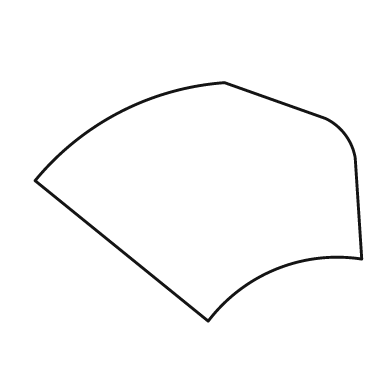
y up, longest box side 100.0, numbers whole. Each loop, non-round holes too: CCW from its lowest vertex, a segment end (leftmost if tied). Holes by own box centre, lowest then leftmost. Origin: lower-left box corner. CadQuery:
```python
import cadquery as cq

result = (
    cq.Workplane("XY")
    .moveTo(53.0, 0.0)
    .threePointArc((74.0, 16.0), (100.0, 19.0))
    .lineTo(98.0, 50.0)
    .threePointArc((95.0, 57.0), (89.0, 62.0))
    .lineTo(58.0, 73.0)
    .threePointArc((26.0, 64.0), (0.0, 43.0))
    .close()
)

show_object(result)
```